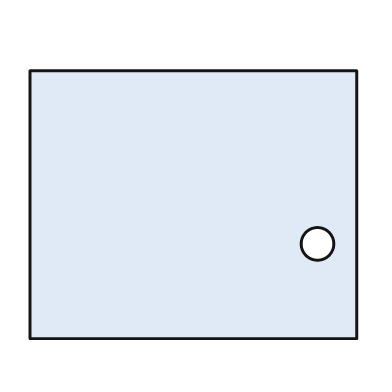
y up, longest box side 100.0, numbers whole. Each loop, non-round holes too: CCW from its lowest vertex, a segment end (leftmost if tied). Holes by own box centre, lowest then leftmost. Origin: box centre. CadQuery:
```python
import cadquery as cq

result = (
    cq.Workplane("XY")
    .moveTo(-50.0, -41.0)
    .lineTo(50.0, -41.0)
    .lineTo(50.0, 41.0)
    .lineTo(-50.0, 41.0)
    .close()
    .moveTo(38.0, -12.0)
    .circle(5.0)
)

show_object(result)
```